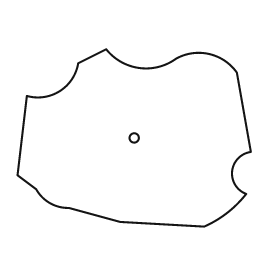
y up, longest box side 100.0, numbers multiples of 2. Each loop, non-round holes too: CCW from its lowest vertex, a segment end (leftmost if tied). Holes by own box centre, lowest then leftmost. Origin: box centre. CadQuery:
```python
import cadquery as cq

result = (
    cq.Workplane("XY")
    .moveTo(30.0, -38.0)
    .threePointArc((40.0, -32.0), (48.0, -24.0))
    .threePointArc((42.0, -14.0), (50.0, -6.0))
    .lineTo(44.0, 28.0)
    .threePointArc((32.0, 36.0), (18.0, 34.0))
    .threePointArc((2.0, 30.0), (-12.0, 38.0))
    .lineTo(-24.0, 32.0)
    .threePointArc((-32.0, 20.0), (-46.0, 18.0))
    .lineTo(-50.0, -16.0)
    .lineTo(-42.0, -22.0)
    .threePointArc((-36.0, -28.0), (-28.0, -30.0))
    .lineTo(-6.0, -36.0)
    .close()
    .moveTo(0.0, 0.0)
    .circle(2.0)
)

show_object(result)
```